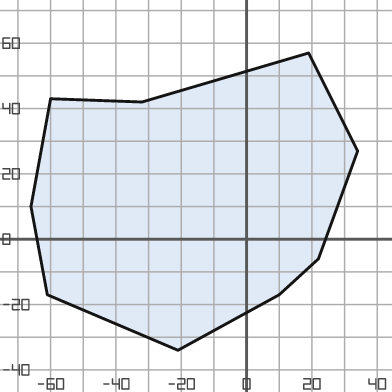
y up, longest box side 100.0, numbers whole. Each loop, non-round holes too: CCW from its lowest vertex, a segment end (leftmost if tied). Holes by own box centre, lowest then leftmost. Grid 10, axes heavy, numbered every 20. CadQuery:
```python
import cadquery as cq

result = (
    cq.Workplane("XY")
    .moveTo(-21.0, -34.0)
    .lineTo(10.0, -17.0)
    .lineTo(22.0, -6.0)
    .lineTo(34.0, 27.0)
    .lineTo(19.0, 57.0)
    .lineTo(-32.0, 42.0)
    .lineTo(-60.0, 43.0)
    .lineTo(-66.0, 10.0)
    .lineTo(-61.0, -17.0)
    .close()
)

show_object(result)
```